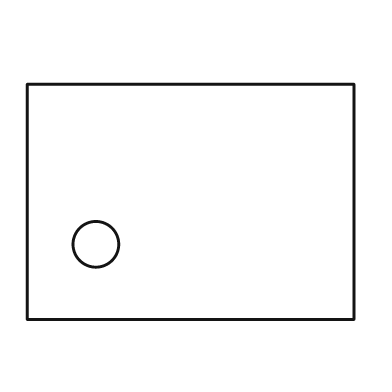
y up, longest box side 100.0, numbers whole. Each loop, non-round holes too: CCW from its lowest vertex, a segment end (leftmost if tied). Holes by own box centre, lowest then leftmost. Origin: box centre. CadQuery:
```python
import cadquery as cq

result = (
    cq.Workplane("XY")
    .moveTo(-50.0, -36.0)
    .lineTo(50.0, -36.0)
    .lineTo(50.0, 36.0)
    .lineTo(-50.0, 36.0)
    .close()
    .moveTo(-29.0, -13.0)
    .circle(7.0)
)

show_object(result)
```